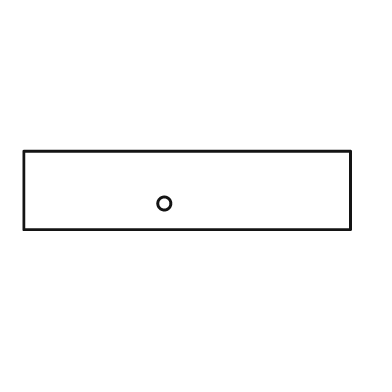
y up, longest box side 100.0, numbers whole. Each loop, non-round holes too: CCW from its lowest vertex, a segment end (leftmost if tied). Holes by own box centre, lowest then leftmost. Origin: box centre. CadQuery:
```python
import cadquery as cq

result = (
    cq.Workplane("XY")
    .moveTo(-50.0, -12.0)
    .lineTo(50.0, -12.0)
    .lineTo(50.0, 12.0)
    .lineTo(-50.0, 12.0)
    .close()
    .moveTo(-7.0, -4.0)
    .circle(2.0)
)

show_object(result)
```